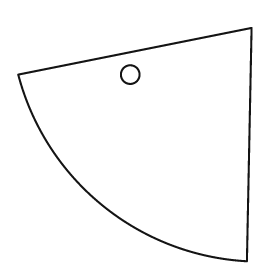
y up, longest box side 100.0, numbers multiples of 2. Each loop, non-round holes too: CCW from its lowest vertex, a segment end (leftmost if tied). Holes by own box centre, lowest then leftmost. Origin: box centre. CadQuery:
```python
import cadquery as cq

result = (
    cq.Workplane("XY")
    .moveTo(48.0, -50.0)
    .lineTo(50.0, 50.0)
    .lineTo(-50.0, 30.0)
    .threePointArc((-14.0, -26.0), (48.0, -50.0))
    .close()
    .moveTo(-2.0, 30.0)
    .circle(4.0)
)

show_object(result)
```